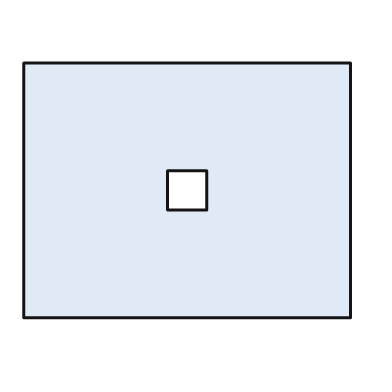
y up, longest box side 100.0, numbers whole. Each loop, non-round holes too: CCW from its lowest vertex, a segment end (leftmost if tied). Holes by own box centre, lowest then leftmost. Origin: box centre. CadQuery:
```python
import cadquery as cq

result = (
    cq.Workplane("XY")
    .moveTo(-50.0, -39.0)
    .lineTo(50.0, -39.0)
    .lineTo(50.0, 39.0)
    .lineTo(-50.0, 39.0)
    .close()
    .moveTo(-6.0, -6.0)
    .lineTo(6.0, -6.0)
    .lineTo(6.0, 6.0)
    .lineTo(-6.0, 6.0)
    .close()
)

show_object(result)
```